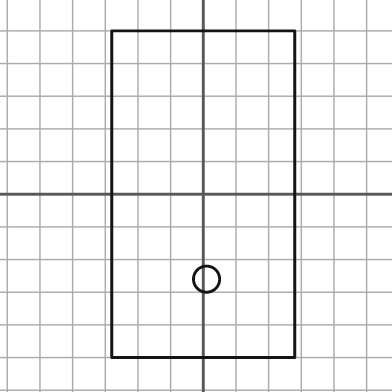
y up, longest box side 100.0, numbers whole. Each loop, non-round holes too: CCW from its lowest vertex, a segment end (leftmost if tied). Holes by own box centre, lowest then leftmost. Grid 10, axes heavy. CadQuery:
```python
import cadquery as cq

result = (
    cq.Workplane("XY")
    .moveTo(-28.0, -50.0)
    .lineTo(28.0, -50.0)
    .lineTo(28.0, 50.0)
    .lineTo(-28.0, 50.0)
    .close()
    .moveTo(1.0, -26.0)
    .circle(4.0)
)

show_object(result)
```